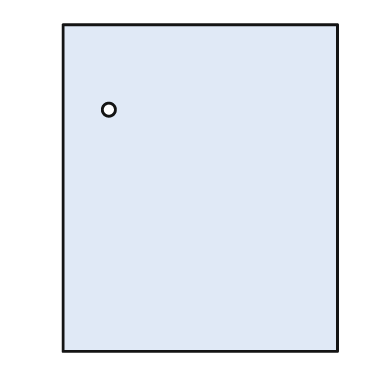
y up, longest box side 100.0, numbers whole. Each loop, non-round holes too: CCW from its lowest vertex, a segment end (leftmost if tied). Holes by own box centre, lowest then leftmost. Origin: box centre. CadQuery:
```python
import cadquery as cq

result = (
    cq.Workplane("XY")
    .moveTo(-42.0, -50.0)
    .lineTo(42.0, -50.0)
    .lineTo(42.0, 50.0)
    .lineTo(-42.0, 50.0)
    .close()
    .moveTo(-28.0, 24.0)
    .circle(2.0)
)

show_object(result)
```